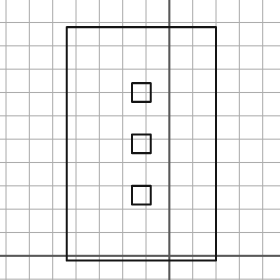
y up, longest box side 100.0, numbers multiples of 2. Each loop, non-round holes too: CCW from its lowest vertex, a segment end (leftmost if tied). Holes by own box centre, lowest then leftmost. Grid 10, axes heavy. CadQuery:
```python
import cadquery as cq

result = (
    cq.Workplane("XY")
    .moveTo(-44.0, -2.0)
    .lineTo(20.0, -2.0)
    .lineTo(20.0, 98.0)
    .lineTo(-44.0, 98.0)
    .close()
    .moveTo(-16.0, 22.0)
    .lineTo(-8.0, 22.0)
    .lineTo(-8.0, 30.0)
    .lineTo(-16.0, 30.0)
    .close()
    .moveTo(-16.0, 44.0)
    .lineTo(-8.0, 44.0)
    .lineTo(-8.0, 52.0)
    .lineTo(-16.0, 52.0)
    .close()
    .moveTo(-16.0, 66.0)
    .lineTo(-8.0, 66.0)
    .lineTo(-8.0, 74.0)
    .lineTo(-16.0, 74.0)
    .close()
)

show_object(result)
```